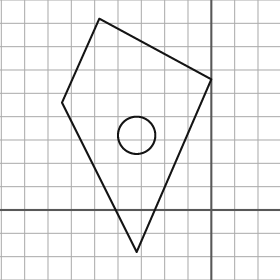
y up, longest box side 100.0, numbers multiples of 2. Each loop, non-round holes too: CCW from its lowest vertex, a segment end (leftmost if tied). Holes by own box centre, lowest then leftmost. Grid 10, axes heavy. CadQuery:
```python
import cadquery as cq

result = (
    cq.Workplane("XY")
    .moveTo(-32.0, -18.0)
    .lineTo(0.0, 56.0)
    .lineTo(-48.0, 82.0)
    .lineTo(-64.0, 46.0)
    .close()
    .moveTo(-32.0, 32.0)
    .circle(8.0)
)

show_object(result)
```